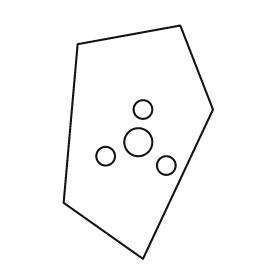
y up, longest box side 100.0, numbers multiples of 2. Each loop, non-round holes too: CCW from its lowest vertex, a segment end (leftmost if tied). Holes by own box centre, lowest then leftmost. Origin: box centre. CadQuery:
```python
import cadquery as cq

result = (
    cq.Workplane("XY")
    .moveTo(2.0, -50.0)
    .lineTo(32.0, 14.0)
    .lineTo(18.0, 50.0)
    .lineTo(-26.0, 42.0)
    .lineTo(-32.0, -26.0)
    .close()
    .moveTo(12.0, -10.0)
    .circle(4.0)
    .moveTo(-14.0, -6.0)
    .circle(4.0)
    .moveTo(0.0, 0.0)
    .circle(6.0)
    .moveTo(2.0, 14.0)
    .circle(4.0)
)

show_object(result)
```